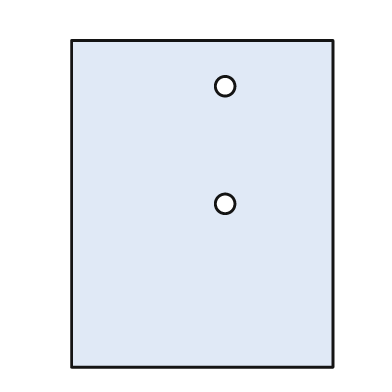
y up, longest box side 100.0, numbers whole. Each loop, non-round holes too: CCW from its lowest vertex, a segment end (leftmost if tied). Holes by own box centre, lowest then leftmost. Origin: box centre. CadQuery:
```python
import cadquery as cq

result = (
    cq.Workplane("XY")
    .moveTo(-40.0, -50.0)
    .lineTo(40.0, -50.0)
    .lineTo(40.0, 50.0)
    .lineTo(-40.0, 50.0)
    .close()
    .moveTo(7.0, 0.0)
    .circle(3.0)
    .moveTo(7.0, 36.0)
    .circle(3.0)
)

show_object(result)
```